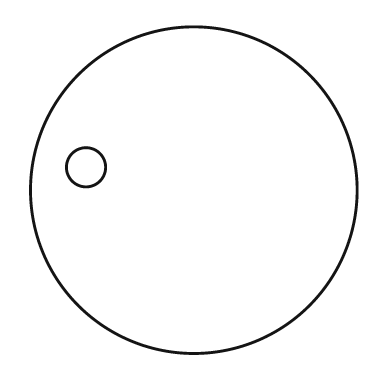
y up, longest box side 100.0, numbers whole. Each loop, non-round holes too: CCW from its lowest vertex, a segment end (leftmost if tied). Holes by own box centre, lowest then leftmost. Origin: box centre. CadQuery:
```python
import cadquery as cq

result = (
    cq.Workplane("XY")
    .moveTo(0.0, 0.0)
    .circle(50.0)
    .moveTo(-33.0, 7.0)
    .circle(6.0)
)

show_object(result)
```